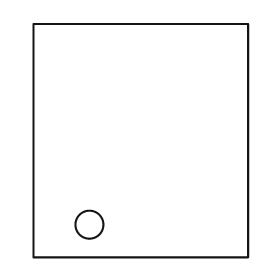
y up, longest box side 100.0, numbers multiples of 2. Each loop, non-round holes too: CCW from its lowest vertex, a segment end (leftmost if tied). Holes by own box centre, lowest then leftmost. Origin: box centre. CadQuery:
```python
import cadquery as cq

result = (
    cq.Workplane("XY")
    .moveTo(-46.0, -50.0)
    .lineTo(46.0, -50.0)
    .lineTo(46.0, 50.0)
    .lineTo(-46.0, 50.0)
    .close()
    .moveTo(-22.0, -36.0)
    .circle(6.0)
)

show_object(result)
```